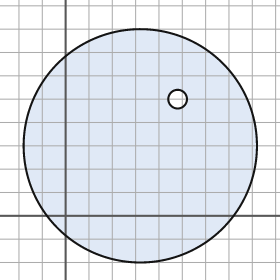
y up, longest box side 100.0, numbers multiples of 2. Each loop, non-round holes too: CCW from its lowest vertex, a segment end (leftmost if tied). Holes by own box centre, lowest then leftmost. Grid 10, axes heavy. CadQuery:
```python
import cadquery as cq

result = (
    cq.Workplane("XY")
    .moveTo(32.0, 30.0)
    .circle(50.0)
    .moveTo(48.0, 50.0)
    .circle(4.0)
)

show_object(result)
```